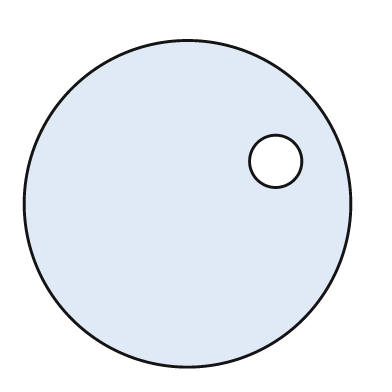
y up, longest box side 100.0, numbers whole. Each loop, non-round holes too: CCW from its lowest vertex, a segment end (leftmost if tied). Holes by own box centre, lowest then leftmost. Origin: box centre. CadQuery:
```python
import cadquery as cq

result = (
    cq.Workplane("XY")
    .moveTo(0.0, 0.0)
    .circle(50.0)
    .moveTo(27.0, 13.0)
    .circle(8.0)
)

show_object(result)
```